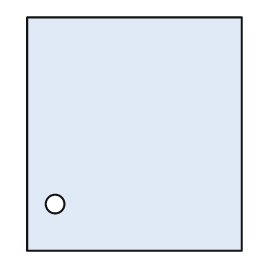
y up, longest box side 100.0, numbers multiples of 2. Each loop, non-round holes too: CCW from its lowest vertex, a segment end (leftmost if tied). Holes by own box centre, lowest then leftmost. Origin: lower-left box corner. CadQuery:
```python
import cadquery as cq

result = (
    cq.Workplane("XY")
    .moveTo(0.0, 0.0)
    .lineTo(92.0, 0.0)
    .lineTo(92.0, 100.0)
    .lineTo(0.0, 100.0)
    .close()
    .moveTo(12.0, 20.0)
    .circle(4.0)
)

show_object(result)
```